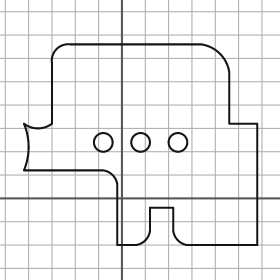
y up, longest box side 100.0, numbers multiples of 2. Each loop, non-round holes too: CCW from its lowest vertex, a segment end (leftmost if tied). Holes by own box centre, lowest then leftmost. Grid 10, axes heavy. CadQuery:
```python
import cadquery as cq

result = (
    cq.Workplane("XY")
    .moveTo(-2.0, -20.0)
    .lineTo(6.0, -20.0)
    .threePointArc((10.0, -18.0), (12.0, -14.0))
    .lineTo(12.0, -4.0)
    .lineTo(22.0, -4.0)
    .lineTo(22.0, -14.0)
    .threePointArc((24.0, -18.0), (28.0, -20.0))
    .lineTo(58.0, -20.0)
    .lineTo(58.0, 32.0)
    .lineTo(46.0, 32.0)
    .lineTo(46.0, 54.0)
    .threePointArc((42.0, 62.0), (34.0, 66.0))
    .lineTo(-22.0, 66.0)
    .threePointArc((-28.0, 64.0), (-30.0, 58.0))
    .lineTo(-30.0, 32.0)
    .threePointArc((-36.0, 30.0), (-42.0, 32.0))
    .threePointArc((-40.0, 22.0), (-42.0, 12.0))
    .lineTo(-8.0, 12.0)
    .threePointArc((-4.0, 10.0), (-2.0, 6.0))
    .close()
    .moveTo(-8.0, 24.0)
    .circle(4.0)
    .moveTo(8.0, 24.0)
    .circle(4.0)
    .moveTo(24.0, 24.0)
    .circle(4.0)
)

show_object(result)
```